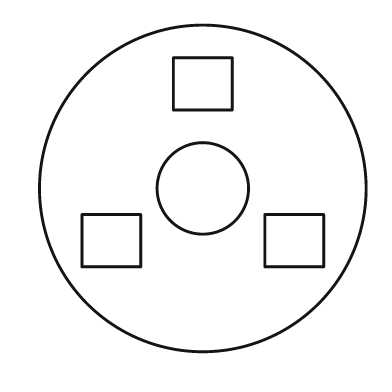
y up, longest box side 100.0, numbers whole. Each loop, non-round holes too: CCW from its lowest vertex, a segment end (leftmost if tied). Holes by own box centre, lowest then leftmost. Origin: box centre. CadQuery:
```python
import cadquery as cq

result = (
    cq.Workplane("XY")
    .moveTo(0.0, 0.0)
    .circle(50.0)
    .moveTo(-37.0, -24.0)
    .lineTo(-19.0, -24.0)
    .lineTo(-19.0, -8.0)
    .lineTo(-37.0, -8.0)
    .close()
    .moveTo(19.0, -24.0)
    .lineTo(37.0, -24.0)
    .lineTo(37.0, -8.0)
    .lineTo(19.0, -8.0)
    .close()
    .moveTo(0.0, 0.0)
    .circle(14.0)
    .moveTo(-9.0, 24.0)
    .lineTo(9.0, 24.0)
    .lineTo(9.0, 40.0)
    .lineTo(-9.0, 40.0)
    .close()
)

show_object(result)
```